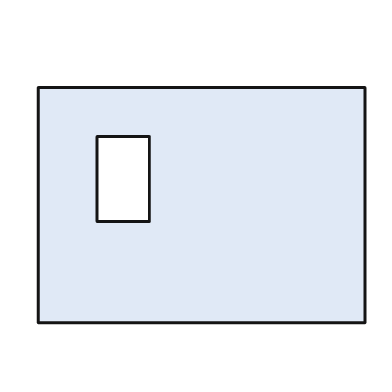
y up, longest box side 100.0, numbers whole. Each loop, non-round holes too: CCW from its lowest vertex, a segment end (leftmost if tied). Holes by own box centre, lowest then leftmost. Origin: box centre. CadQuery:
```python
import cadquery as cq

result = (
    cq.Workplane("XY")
    .moveTo(-50.0, -36.0)
    .lineTo(50.0, -36.0)
    .lineTo(50.0, 36.0)
    .lineTo(-50.0, 36.0)
    .close()
    .moveTo(-32.0, -5.0)
    .lineTo(-16.0, -5.0)
    .lineTo(-16.0, 21.0)
    .lineTo(-32.0, 21.0)
    .close()
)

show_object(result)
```